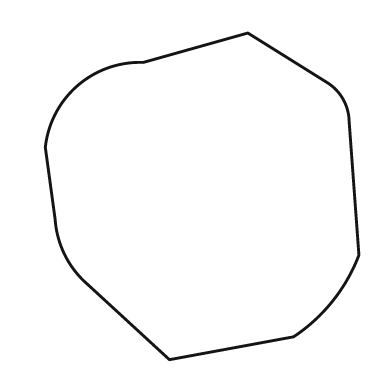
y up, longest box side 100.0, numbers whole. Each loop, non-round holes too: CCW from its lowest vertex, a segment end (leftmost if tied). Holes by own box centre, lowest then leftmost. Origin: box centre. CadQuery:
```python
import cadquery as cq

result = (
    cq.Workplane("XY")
    .moveTo(-10.0, -50.0)
    .lineTo(28.0, -43.0)
    .threePointArc((40.0, -32.0), (48.0, -18.0))
    .lineTo(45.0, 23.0)
    .threePointArc((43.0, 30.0), (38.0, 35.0))
    .lineTo(14.0, 50.0)
    .lineTo(-18.0, 41.0)
    .threePointArc((-38.0, 34.0), (-48.0, 15.0))
    .lineTo(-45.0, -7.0)
    .threePointArc((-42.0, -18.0), (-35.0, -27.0))
    .close()
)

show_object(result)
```